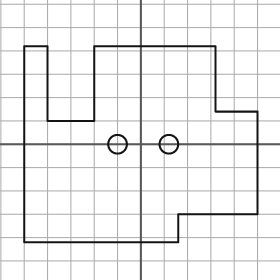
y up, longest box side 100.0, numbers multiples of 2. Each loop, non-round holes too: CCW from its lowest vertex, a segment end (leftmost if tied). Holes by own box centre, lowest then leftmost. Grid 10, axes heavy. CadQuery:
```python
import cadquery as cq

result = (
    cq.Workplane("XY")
    .moveTo(-50.0, -42.0)
    .lineTo(16.0, -42.0)
    .lineTo(16.0, -30.0)
    .lineTo(50.0, -30.0)
    .lineTo(50.0, 14.0)
    .lineTo(32.0, 14.0)
    .lineTo(32.0, 42.0)
    .lineTo(-20.0, 42.0)
    .lineTo(-20.0, 10.0)
    .lineTo(-40.0, 10.0)
    .lineTo(-40.0, 42.0)
    .lineTo(-50.0, 42.0)
    .close()
    .moveTo(-10.0, 0.0)
    .circle(4.0)
    .moveTo(12.0, 0.0)
    .circle(4.0)
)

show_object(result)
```